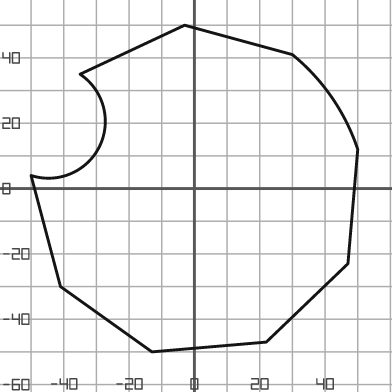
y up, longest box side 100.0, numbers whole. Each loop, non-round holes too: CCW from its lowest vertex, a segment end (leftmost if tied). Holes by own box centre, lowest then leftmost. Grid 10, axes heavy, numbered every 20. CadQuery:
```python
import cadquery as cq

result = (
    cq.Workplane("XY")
    .moveTo(-13.0, -50.0)
    .lineTo(22.0, -47.0)
    .lineTo(47.0, -23.0)
    .lineTo(50.0, 12.0)
    .threePointArc((42.0, 28.0), (30.0, 41.0))
    .lineTo(-3.0, 50.0)
    .lineTo(-35.0, 35.0)
    .threePointArc((-29.0, 13.0), (-50.0, 4.0))
    .lineTo(-41.0, -30.0)
    .close()
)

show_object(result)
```